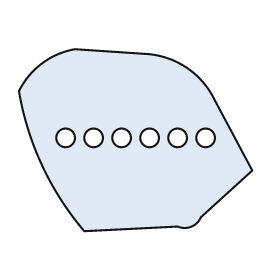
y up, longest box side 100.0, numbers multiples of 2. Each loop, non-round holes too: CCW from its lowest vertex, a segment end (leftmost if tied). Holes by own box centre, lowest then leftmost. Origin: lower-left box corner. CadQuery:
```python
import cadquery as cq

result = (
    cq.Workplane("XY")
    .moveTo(28.0, 0.0)
    .lineTo(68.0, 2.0)
    .threePointArc((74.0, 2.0), (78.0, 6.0))
    .lineTo(100.0, 26.0)
    .lineTo(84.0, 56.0)
    .threePointArc((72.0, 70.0), (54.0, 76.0))
    .lineTo(24.0, 78.0)
    .threePointArc((10.0, 72.0), (0.0, 60.0))
    .threePointArc((10.0, 28.0), (28.0, 0.0))
    .close()
    .moveTo(20.0, 40.0)
    .circle(4.0)
    .moveTo(32.0, 40.0)
    .circle(4.0)
    .moveTo(44.0, 40.0)
    .circle(4.0)
    .moveTo(56.0, 40.0)
    .circle(4.0)
    .moveTo(68.0, 40.0)
    .circle(4.0)
    .moveTo(80.0, 40.0)
    .circle(4.0)
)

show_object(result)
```